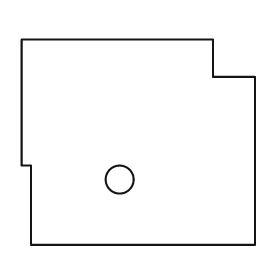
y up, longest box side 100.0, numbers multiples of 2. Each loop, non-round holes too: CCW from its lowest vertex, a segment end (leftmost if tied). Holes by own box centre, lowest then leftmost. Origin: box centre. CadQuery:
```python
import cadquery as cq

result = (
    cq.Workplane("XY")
    .moveTo(-46.0, -44.0)
    .lineTo(50.0, -44.0)
    .lineTo(50.0, 28.0)
    .lineTo(32.0, 28.0)
    .lineTo(32.0, 44.0)
    .lineTo(-50.0, 44.0)
    .lineTo(-50.0, -10.0)
    .lineTo(-46.0, -10.0)
    .close()
    .moveTo(-8.0, -16.0)
    .circle(6.0)
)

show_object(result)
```